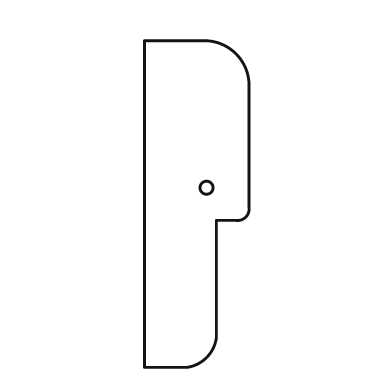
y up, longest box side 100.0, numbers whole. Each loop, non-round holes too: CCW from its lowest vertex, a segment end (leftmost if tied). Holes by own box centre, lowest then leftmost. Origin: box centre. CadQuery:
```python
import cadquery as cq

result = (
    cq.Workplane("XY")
    .moveTo(-16.0, -50.0)
    .lineTo(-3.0, -50.0)
    .threePointArc((3.0, -47.0), (6.0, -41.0))
    .lineTo(6.0, -5.0)
    .lineTo(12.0, -5.0)
    .threePointArc((15.0, -4.0), (16.0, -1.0))
    .lineTo(16.0, 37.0)
    .threePointArc((12.0, 46.0), (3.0, 50.0))
    .lineTo(-16.0, 50.0)
    .close()
    .moveTo(3.0, 5.0)
    .circle(2.0)
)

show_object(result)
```